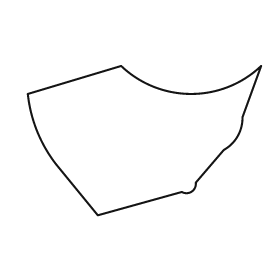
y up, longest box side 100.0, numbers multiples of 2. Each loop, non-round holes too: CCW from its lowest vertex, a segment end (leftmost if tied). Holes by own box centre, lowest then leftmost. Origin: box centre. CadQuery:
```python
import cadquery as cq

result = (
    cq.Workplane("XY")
    .moveTo(-20.0, -32.0)
    .lineTo(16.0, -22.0)
    .threePointArc((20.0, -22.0), (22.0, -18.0))
    .lineTo(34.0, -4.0)
    .threePointArc((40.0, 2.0), (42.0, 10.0))
    .lineTo(50.0, 32.0)
    .threePointArc((20.0, 20.0), (-10.0, 32.0))
    .lineTo(-50.0, 20.0)
    .threePointArc((-46.0, 4.0), (-38.0, -10.0))
    .close()
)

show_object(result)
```